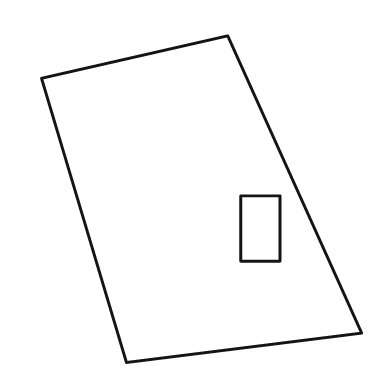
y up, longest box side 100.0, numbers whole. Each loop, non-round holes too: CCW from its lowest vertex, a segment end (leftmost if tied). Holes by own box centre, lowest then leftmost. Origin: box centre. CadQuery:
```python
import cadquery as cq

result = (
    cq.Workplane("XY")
    .moveTo(-23.0, -50.0)
    .lineTo(49.0, -41.0)
    .lineTo(8.0, 50.0)
    .lineTo(-49.0, 37.0)
    .close()
    .moveTo(12.0, -19.0)
    .lineTo(24.0, -19.0)
    .lineTo(24.0, 1.0)
    .lineTo(12.0, 1.0)
    .close()
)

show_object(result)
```